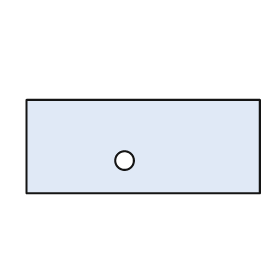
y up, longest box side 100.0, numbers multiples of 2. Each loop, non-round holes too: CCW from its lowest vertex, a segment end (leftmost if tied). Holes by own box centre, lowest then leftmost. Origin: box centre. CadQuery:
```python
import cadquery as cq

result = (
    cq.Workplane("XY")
    .moveTo(-50.0, -20.0)
    .lineTo(50.0, -20.0)
    .lineTo(50.0, 20.0)
    .lineTo(-50.0, 20.0)
    .close()
    .moveTo(-8.0, -6.0)
    .circle(4.0)
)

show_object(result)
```